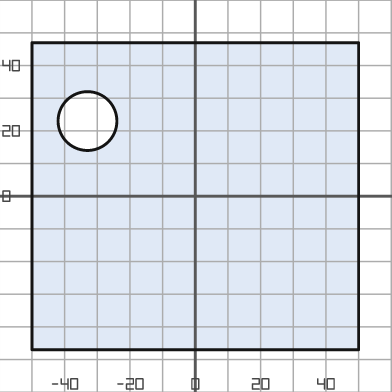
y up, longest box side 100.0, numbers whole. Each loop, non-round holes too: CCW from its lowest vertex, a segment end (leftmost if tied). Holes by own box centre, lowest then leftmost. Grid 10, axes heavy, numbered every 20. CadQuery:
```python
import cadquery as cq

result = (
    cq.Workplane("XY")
    .moveTo(-50.0, -47.0)
    .lineTo(50.0, -47.0)
    .lineTo(50.0, 47.0)
    .lineTo(-50.0, 47.0)
    .close()
    .moveTo(-33.0, 23.0)
    .circle(9.0)
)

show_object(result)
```